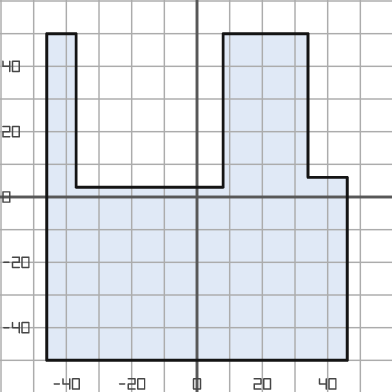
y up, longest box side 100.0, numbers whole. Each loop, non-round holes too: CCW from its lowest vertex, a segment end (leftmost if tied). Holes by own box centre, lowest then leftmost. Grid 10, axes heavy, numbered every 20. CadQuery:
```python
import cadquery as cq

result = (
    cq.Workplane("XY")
    .moveTo(-46.0, -50.0)
    .lineTo(46.0, -50.0)
    .lineTo(46.0, 6.0)
    .lineTo(34.0, 6.0)
    .lineTo(34.0, 50.0)
    .lineTo(8.0, 50.0)
    .lineTo(8.0, 3.0)
    .lineTo(-37.0, 3.0)
    .lineTo(-37.0, 50.0)
    .lineTo(-46.0, 50.0)
    .close()
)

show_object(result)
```